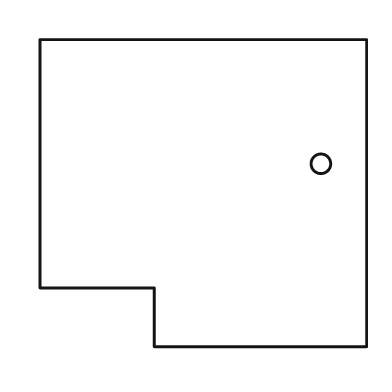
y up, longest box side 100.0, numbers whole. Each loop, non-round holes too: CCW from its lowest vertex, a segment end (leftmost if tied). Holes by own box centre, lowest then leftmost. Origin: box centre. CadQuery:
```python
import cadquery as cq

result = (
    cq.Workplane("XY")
    .moveTo(-15.0, -47.0)
    .lineTo(50.0, -47.0)
    .lineTo(50.0, 47.0)
    .lineTo(-50.0, 47.0)
    .lineTo(-50.0, -29.0)
    .lineTo(-15.0, -29.0)
    .close()
    .moveTo(36.0, 9.0)
    .circle(3.0)
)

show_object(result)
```